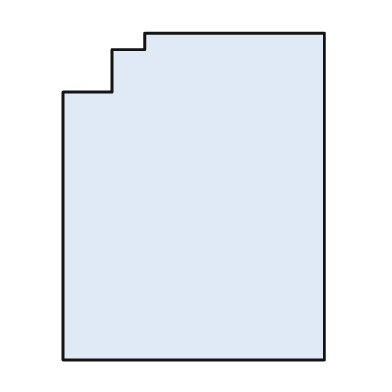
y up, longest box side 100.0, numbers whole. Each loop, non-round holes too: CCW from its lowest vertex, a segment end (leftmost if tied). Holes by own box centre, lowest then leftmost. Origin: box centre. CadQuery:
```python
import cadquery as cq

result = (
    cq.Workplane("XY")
    .moveTo(-40.0, -50.0)
    .lineTo(40.0, -50.0)
    .lineTo(40.0, 50.0)
    .lineTo(-15.0, 50.0)
    .lineTo(-15.0, 45.0)
    .lineTo(-25.0, 45.0)
    .lineTo(-25.0, 32.0)
    .lineTo(-40.0, 32.0)
    .close()
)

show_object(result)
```